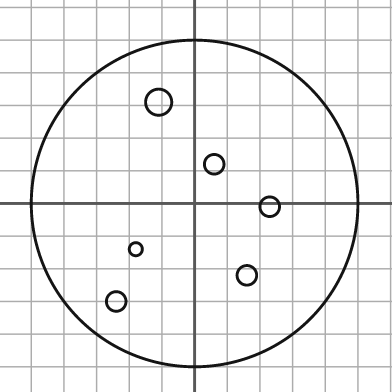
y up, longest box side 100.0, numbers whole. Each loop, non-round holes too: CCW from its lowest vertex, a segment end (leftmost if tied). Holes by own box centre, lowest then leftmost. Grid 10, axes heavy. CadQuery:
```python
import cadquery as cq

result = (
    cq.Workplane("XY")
    .moveTo(0.0, 0.0)
    .circle(50.0)
    .moveTo(-24.0, -30.0)
    .circle(3.0)
    .moveTo(16.0, -22.0)
    .circle(3.0)
    .moveTo(-18.0, -14.0)
    .circle(2.0)
    .moveTo(23.0, -1.0)
    .circle(3.0)
    .moveTo(6.0, 12.0)
    .circle(3.0)
    .moveTo(-11.0, 31.0)
    .circle(4.0)
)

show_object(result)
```